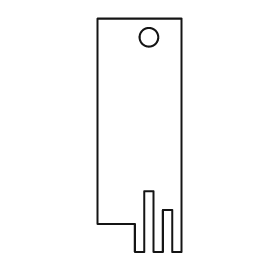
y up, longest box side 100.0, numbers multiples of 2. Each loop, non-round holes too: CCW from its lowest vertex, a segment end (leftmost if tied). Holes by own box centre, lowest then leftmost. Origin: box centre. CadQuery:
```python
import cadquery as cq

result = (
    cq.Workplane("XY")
    .moveTo(-2.0, -50.0)
    .lineTo(2.0, -50.0)
    .lineTo(2.0, -24.0)
    .lineTo(6.0, -24.0)
    .lineTo(6.0, -50.0)
    .lineTo(10.0, -50.0)
    .lineTo(10.0, -32.0)
    .lineTo(14.0, -32.0)
    .lineTo(14.0, -50.0)
    .lineTo(18.0, -50.0)
    .lineTo(18.0, 50.0)
    .lineTo(-18.0, 50.0)
    .lineTo(-18.0, -38.0)
    .lineTo(-2.0, -38.0)
    .close()
    .moveTo(4.0, 42.0)
    .circle(4.0)
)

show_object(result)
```